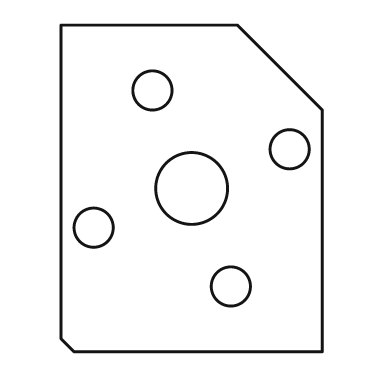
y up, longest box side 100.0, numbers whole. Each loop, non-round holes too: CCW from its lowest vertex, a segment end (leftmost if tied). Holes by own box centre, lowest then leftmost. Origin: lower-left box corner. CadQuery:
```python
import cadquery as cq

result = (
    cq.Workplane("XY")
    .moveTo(4.0, 0.0)
    .lineTo(80.0, 0.0)
    .lineTo(80.0, 74.0)
    .lineTo(54.0, 100.0)
    .lineTo(0.0, 100.0)
    .lineTo(0.0, 4.0)
    .close()
    .moveTo(52.0, 20.0)
    .circle(6.0)
    .moveTo(10.0, 38.0)
    .circle(6.0)
    .moveTo(40.0, 50.0)
    .circle(11.0)
    .moveTo(70.0, 62.0)
    .circle(6.0)
    .moveTo(28.0, 80.0)
    .circle(6.0)
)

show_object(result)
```